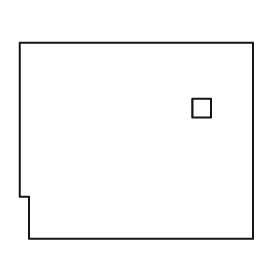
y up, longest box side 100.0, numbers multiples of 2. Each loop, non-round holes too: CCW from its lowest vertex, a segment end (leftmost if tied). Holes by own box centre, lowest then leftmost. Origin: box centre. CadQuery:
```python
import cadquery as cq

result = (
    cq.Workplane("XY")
    .moveTo(-46.0, -42.0)
    .lineTo(50.0, -42.0)
    .lineTo(50.0, 42.0)
    .lineTo(-50.0, 42.0)
    .lineTo(-50.0, -24.0)
    .lineTo(-46.0, -24.0)
    .close()
    .moveTo(24.0, 10.0)
    .lineTo(32.0, 10.0)
    .lineTo(32.0, 18.0)
    .lineTo(24.0, 18.0)
    .close()
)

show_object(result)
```